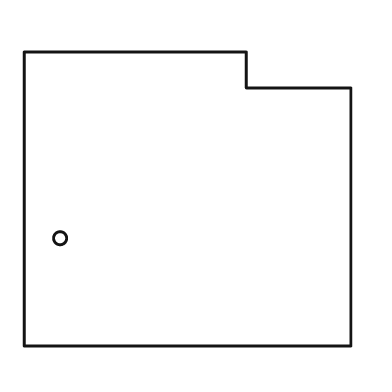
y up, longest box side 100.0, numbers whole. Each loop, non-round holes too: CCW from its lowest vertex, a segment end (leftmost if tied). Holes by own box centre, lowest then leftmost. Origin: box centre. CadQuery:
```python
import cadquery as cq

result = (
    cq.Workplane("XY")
    .moveTo(-50.0, -45.0)
    .lineTo(50.0, -45.0)
    .lineTo(50.0, 34.0)
    .lineTo(18.0, 34.0)
    .lineTo(18.0, 45.0)
    .lineTo(-50.0, 45.0)
    .close()
    .moveTo(-39.0, -12.0)
    .circle(2.0)
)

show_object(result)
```